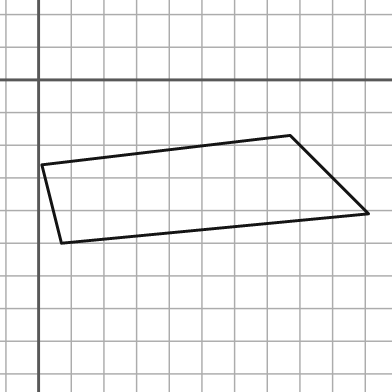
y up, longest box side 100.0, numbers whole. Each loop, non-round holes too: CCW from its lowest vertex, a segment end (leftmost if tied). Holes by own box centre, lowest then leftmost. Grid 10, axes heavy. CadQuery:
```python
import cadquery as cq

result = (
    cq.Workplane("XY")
    .moveTo(7.0, -50.0)
    .lineTo(101.0, -41.0)
    .lineTo(77.0, -17.0)
    .lineTo(1.0, -26.0)
    .close()
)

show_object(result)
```